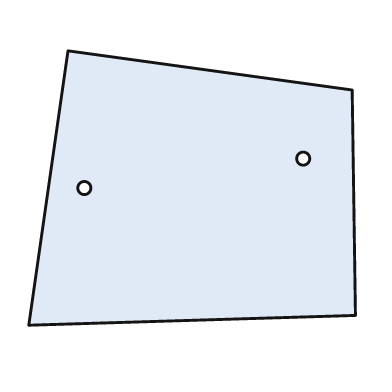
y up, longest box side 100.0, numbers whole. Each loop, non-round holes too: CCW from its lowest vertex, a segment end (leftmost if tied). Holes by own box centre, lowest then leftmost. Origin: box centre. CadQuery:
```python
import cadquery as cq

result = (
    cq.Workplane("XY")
    .moveTo(-50.0, -42.0)
    .lineTo(50.0, -39.0)
    .lineTo(49.0, 30.0)
    .lineTo(-38.0, 42.0)
    .close()
    .moveTo(-33.0, 0.0)
    .circle(2.0)
    .moveTo(34.0, 9.0)
    .circle(2.0)
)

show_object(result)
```